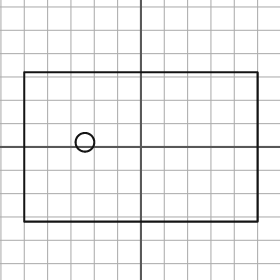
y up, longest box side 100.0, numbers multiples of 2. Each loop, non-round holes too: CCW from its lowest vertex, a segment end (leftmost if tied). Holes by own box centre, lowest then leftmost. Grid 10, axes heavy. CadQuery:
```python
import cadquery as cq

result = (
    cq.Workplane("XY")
    .moveTo(-50.0, -32.0)
    .lineTo(50.0, -32.0)
    .lineTo(50.0, 32.0)
    .lineTo(-50.0, 32.0)
    .close()
    .moveTo(-24.0, 2.0)
    .circle(4.0)
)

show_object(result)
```